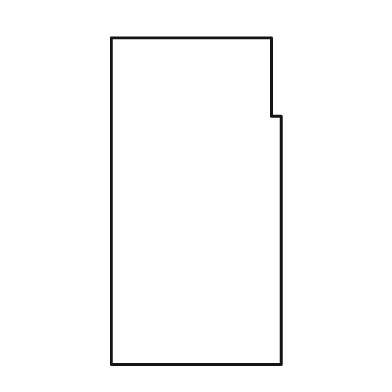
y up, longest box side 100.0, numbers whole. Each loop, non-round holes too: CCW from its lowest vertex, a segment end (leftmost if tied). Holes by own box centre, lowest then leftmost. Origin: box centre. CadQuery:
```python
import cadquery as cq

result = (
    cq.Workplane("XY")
    .moveTo(-26.0, -50.0)
    .lineTo(26.0, -50.0)
    .lineTo(26.0, 26.0)
    .lineTo(23.0, 26.0)
    .lineTo(23.0, 50.0)
    .lineTo(-26.0, 50.0)
    .close()
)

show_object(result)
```